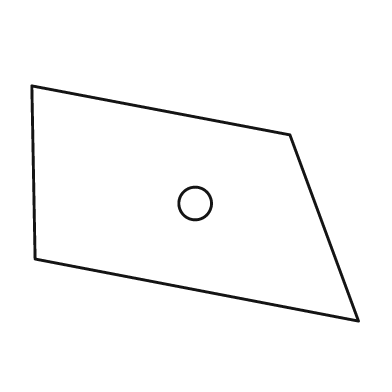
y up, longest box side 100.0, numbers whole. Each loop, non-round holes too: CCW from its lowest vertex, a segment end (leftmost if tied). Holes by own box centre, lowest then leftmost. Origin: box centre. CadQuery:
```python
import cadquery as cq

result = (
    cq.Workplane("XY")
    .moveTo(50.0, -36.0)
    .lineTo(29.0, 21.0)
    .lineTo(-50.0, 36.0)
    .lineTo(-49.0, -17.0)
    .close()
    .moveTo(0.0, 0.0)
    .circle(5.0)
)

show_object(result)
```